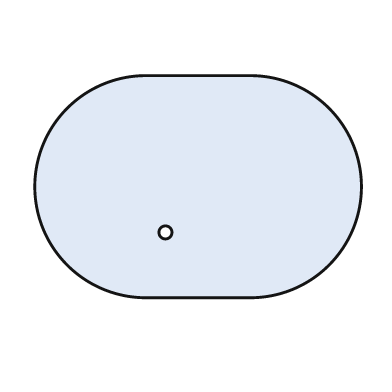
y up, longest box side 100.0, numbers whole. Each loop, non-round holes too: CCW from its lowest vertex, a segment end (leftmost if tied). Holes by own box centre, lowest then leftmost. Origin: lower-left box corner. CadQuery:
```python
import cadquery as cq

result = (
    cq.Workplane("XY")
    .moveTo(34.0, 0.0)
    .lineTo(66.0, 0.0)
    .threePointArc((100.0, 34.0), (66.0, 68.0))
    .lineTo(34.0, 68.0)
    .threePointArc((0.0, 34.0), (34.0, 0.0))
    .close()
    .moveTo(40.0, 20.0)
    .circle(2.0)
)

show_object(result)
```